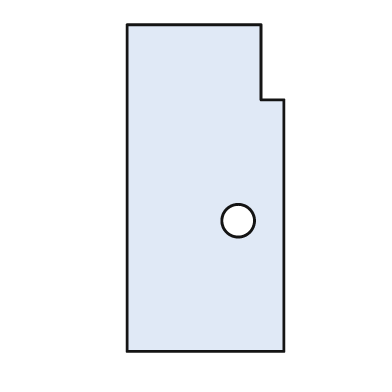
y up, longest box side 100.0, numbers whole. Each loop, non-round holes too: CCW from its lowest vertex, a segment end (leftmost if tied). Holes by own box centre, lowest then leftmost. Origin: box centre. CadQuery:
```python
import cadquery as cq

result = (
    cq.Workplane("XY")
    .moveTo(-24.0, -50.0)
    .lineTo(24.0, -50.0)
    .lineTo(24.0, 27.0)
    .lineTo(17.0, 27.0)
    .lineTo(17.0, 50.0)
    .lineTo(-24.0, 50.0)
    .close()
    .moveTo(10.0, -10.0)
    .circle(5.0)
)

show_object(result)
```